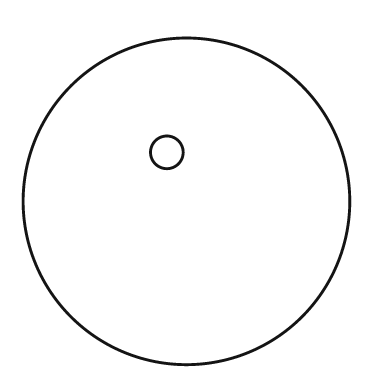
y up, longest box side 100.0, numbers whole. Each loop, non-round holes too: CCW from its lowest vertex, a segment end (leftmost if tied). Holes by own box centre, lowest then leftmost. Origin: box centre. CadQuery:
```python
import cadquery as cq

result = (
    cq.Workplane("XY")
    .moveTo(0.0, 0.0)
    .circle(50.0)
    .moveTo(-6.0, 15.0)
    .circle(5.0)
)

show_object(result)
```